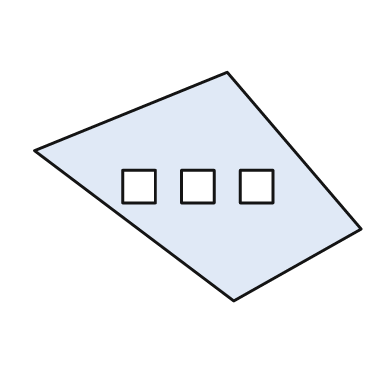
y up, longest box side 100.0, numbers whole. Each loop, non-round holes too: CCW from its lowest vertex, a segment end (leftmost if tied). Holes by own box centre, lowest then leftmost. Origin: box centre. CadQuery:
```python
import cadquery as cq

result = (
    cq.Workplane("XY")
    .moveTo(11.0, -35.0)
    .lineTo(50.0, -13.0)
    .lineTo(9.0, 35.0)
    .lineTo(-50.0, 11.0)
    .close()
    .moveTo(-23.0, -5.0)
    .lineTo(-13.0, -5.0)
    .lineTo(-13.0, 5.0)
    .lineTo(-23.0, 5.0)
    .close()
    .moveTo(-5.0, -5.0)
    .lineTo(5.0, -5.0)
    .lineTo(5.0, 5.0)
    .lineTo(-5.0, 5.0)
    .close()
    .moveTo(13.0, -5.0)
    .lineTo(23.0, -5.0)
    .lineTo(23.0, 5.0)
    .lineTo(13.0, 5.0)
    .close()
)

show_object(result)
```